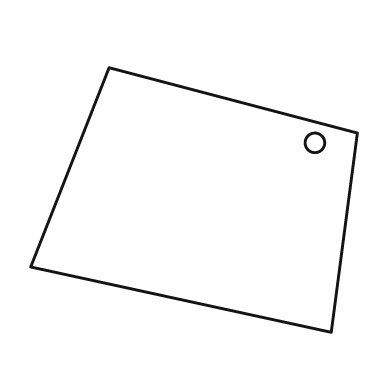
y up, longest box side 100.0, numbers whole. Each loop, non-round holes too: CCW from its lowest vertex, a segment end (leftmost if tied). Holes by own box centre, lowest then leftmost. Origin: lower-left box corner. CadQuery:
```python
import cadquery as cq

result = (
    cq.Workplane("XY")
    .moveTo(92.0, 0.0)
    .lineTo(100.0, 61.0)
    .lineTo(24.0, 81.0)
    .lineTo(0.0, 20.0)
    .close()
    .moveTo(87.0, 58.0)
    .circle(3.0)
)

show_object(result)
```